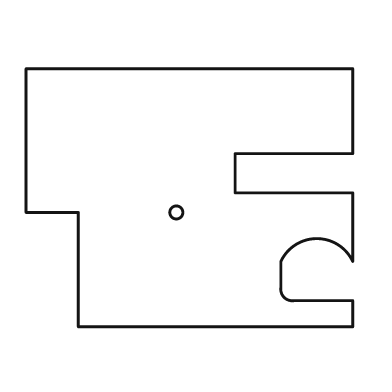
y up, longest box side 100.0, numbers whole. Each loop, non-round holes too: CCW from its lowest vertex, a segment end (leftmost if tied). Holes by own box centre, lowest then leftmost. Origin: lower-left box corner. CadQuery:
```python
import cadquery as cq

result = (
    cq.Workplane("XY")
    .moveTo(16.0, 0.0)
    .lineTo(100.0, 0.0)
    .lineTo(100.0, 8.0)
    .lineTo(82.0, 8.0)
    .threePointArc((79.0, 9.0), (78.0, 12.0))
    .lineTo(78.0, 20.0)
    .threePointArc((89.0, 27.0), (100.0, 20.0))
    .lineTo(100.0, 41.0)
    .lineTo(64.0, 41.0)
    .lineTo(64.0, 53.0)
    .lineTo(100.0, 53.0)
    .lineTo(100.0, 79.0)
    .lineTo(0.0, 79.0)
    .lineTo(0.0, 35.0)
    .lineTo(16.0, 35.0)
    .close()
    .moveTo(46.0, 35.0)
    .circle(2.0)
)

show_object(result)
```